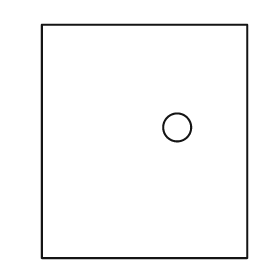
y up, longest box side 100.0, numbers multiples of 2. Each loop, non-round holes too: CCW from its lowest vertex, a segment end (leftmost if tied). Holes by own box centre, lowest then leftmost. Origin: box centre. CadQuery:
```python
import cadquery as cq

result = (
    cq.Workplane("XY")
    .moveTo(-44.0, -50.0)
    .lineTo(44.0, -50.0)
    .lineTo(44.0, 50.0)
    .lineTo(-44.0, 50.0)
    .close()
    .moveTo(14.0, 6.0)
    .circle(6.0)
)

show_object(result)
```